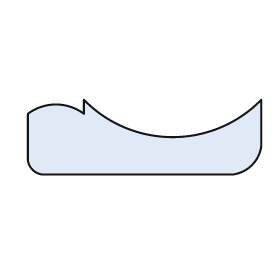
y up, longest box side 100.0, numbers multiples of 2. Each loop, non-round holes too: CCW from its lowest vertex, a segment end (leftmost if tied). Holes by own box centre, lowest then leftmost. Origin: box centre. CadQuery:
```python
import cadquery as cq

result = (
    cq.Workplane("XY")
    .moveTo(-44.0, -16.0)
    .lineTo(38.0, -16.0)
    .threePointArc((46.0, -12.0), (50.0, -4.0))
    .lineTo(50.0, 16.0)
    .threePointArc((12.0, 0.0), (-26.0, 16.0))
    .lineTo(-26.0, 10.0)
    .threePointArc((-38.0, 14.0), (-50.0, 10.0))
    .lineTo(-50.0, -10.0)
    .threePointArc((-48.0, -14.0), (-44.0, -16.0))
    .close()
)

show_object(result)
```